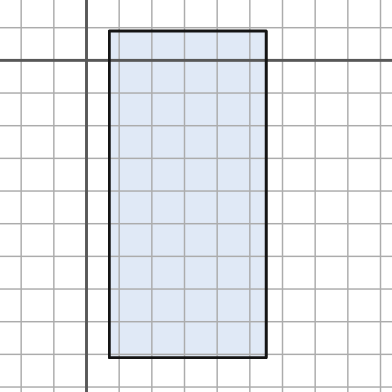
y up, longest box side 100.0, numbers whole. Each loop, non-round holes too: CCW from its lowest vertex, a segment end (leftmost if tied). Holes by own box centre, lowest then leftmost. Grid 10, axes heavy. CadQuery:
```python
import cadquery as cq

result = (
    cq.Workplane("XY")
    .moveTo(7.0, -91.0)
    .lineTo(55.0, -91.0)
    .lineTo(55.0, 9.0)
    .lineTo(7.0, 9.0)
    .close()
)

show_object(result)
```